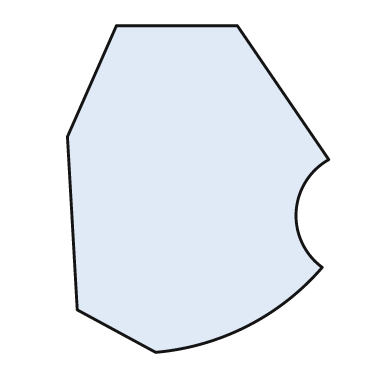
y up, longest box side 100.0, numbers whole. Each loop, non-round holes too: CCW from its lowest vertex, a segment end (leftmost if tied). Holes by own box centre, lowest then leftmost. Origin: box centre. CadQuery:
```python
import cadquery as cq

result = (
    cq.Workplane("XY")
    .moveTo(-13.0, -50.0)
    .threePointArc((15.0, -42.0), (38.0, -24.0))
    .threePointArc((30.0, -7.0), (40.0, 9.0))
    .lineTo(12.0, 50.0)
    .lineTo(-25.0, 50.0)
    .lineTo(-40.0, 16.0)
    .lineTo(-37.0, -37.0)
    .close()
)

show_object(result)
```